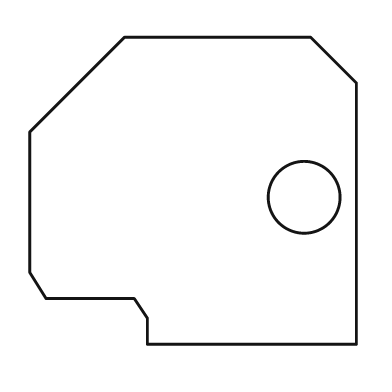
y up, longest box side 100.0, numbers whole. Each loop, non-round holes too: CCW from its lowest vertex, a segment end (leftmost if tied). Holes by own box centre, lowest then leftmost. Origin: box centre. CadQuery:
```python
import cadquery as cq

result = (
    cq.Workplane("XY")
    .moveTo(-14.0, -47.0)
    .lineTo(50.0, -47.0)
    .lineTo(50.0, 33.0)
    .lineTo(36.0, 47.0)
    .lineTo(-21.0, 47.0)
    .lineTo(-50.0, 18.0)
    .lineTo(-50.0, -25.0)
    .lineTo(-45.0, -33.0)
    .lineTo(-18.0, -33.0)
    .lineTo(-14.0, -39.0)
    .close()
    .moveTo(34.0, -2.0)
    .circle(11.0)
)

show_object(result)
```